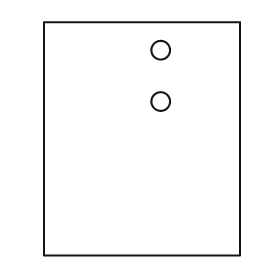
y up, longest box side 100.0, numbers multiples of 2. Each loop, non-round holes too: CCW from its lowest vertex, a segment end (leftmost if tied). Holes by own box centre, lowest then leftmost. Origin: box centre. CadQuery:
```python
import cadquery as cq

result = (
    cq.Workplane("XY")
    .moveTo(-42.0, -50.0)
    .lineTo(42.0, -50.0)
    .lineTo(42.0, 50.0)
    .lineTo(-42.0, 50.0)
    .close()
    .moveTo(8.0, 16.0)
    .circle(4.0)
    .moveTo(8.0, 38.0)
    .circle(4.0)
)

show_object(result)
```